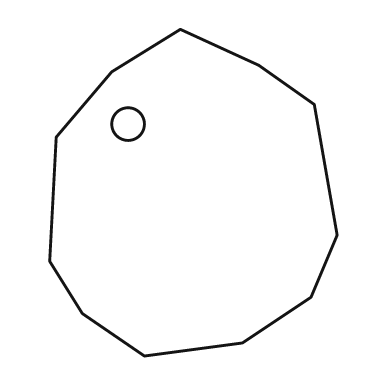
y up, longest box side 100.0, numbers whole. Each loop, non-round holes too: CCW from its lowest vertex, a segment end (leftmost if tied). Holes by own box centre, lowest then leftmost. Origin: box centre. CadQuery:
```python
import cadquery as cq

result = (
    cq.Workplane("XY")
    .moveTo(-15.0, -50.0)
    .lineTo(15.0, -46.0)
    .lineTo(36.0, -32.0)
    .lineTo(44.0, -13.0)
    .lineTo(37.0, 27.0)
    .lineTo(20.0, 39.0)
    .lineTo(-4.0, 50.0)
    .lineTo(-25.0, 37.0)
    .lineTo(-42.0, 17.0)
    .lineTo(-44.0, -21.0)
    .lineTo(-34.0, -37.0)
    .close()
    .moveTo(-20.0, 21.0)
    .circle(5.0)
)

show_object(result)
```